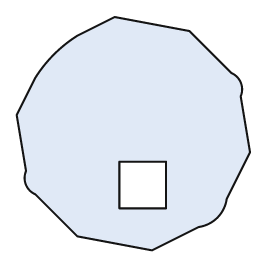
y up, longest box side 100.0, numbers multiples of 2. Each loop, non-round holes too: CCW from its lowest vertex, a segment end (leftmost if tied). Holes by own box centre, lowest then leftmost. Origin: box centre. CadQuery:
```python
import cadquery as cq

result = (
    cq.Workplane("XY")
    .moveTo(8.0, -50.0)
    .lineTo(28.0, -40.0)
    .threePointArc((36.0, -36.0), (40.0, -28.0))
    .lineTo(50.0, -8.0)
    .lineTo(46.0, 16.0)
    .threePointArc((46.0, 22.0), (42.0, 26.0))
    .lineTo(24.0, 44.0)
    .lineTo(-8.0, 50.0)
    .lineTo(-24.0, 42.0)
    .threePointArc((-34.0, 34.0), (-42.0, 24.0))
    .lineTo(-50.0, 8.0)
    .lineTo(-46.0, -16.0)
    .threePointArc((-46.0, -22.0), (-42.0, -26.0))
    .lineTo(-24.0, -44.0)
    .close()
    .moveTo(-6.0, -32.0)
    .lineTo(14.0, -32.0)
    .lineTo(14.0, -12.0)
    .lineTo(-6.0, -12.0)
    .close()
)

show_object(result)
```